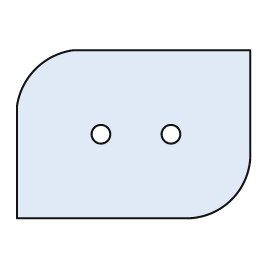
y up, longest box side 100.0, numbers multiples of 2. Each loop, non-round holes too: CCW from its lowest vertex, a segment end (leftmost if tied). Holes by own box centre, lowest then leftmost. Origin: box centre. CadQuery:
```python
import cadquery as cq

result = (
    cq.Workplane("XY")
    .moveTo(-50.0, -36.0)
    .lineTo(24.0, -36.0)
    .threePointArc((42.0, -28.0), (50.0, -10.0))
    .lineTo(50.0, 36.0)
    .lineTo(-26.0, 36.0)
    .threePointArc((-42.0, 28.0), (-50.0, 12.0))
    .close()
    .moveTo(-14.0, 0.0)
    .circle(4.0)
    .moveTo(16.0, 0.0)
    .circle(4.0)
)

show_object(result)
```